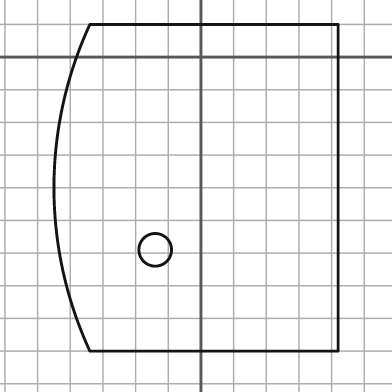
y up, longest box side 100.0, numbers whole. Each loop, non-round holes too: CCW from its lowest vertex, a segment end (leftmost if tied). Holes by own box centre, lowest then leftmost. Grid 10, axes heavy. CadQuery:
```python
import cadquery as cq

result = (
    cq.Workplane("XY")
    .moveTo(-34.0, -90.0)
    .lineTo(42.0, -90.0)
    .lineTo(42.0, 10.0)
    .lineTo(-34.0, 10.0)
    .threePointArc((-45.0, -40.0), (-34.0, -90.0))
    .close()
    .moveTo(-14.0, -59.0)
    .circle(5.0)
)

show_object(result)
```